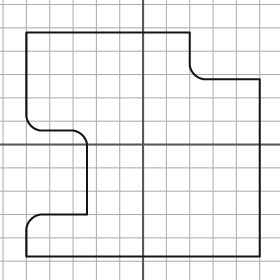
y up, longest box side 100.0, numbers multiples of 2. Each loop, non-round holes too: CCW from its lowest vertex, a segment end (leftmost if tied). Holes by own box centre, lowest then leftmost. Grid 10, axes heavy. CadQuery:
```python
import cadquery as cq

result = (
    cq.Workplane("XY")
    .moveTo(-50.0, -48.0)
    .lineTo(50.0, -48.0)
    .lineTo(50.0, 28.0)
    .lineTo(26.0, 28.0)
    .threePointArc((22.0, 30.0), (20.0, 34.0))
    .lineTo(20.0, 48.0)
    .lineTo(-50.0, 48.0)
    .lineTo(-50.0, 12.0)
    .threePointArc((-48.0, 8.0), (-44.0, 6.0))
    .lineTo(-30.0, 6.0)
    .threePointArc((-26.0, 4.0), (-24.0, 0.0))
    .lineTo(-24.0, -30.0)
    .lineTo(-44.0, -30.0)
    .threePointArc((-48.0, -32.0), (-50.0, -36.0))
    .close()
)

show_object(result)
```